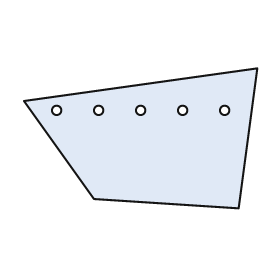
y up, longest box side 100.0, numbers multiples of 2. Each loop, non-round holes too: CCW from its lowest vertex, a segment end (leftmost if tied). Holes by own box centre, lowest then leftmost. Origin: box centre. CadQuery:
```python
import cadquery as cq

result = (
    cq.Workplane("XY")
    .moveTo(42.0, -30.0)
    .lineTo(50.0, 30.0)
    .lineTo(-50.0, 16.0)
    .lineTo(-20.0, -26.0)
    .close()
    .moveTo(-36.0, 12.0)
    .circle(2.0)
    .moveTo(-18.0, 12.0)
    .circle(2.0)
    .moveTo(0.0, 12.0)
    .circle(2.0)
    .moveTo(18.0, 12.0)
    .circle(2.0)
    .moveTo(36.0, 12.0)
    .circle(2.0)
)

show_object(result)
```